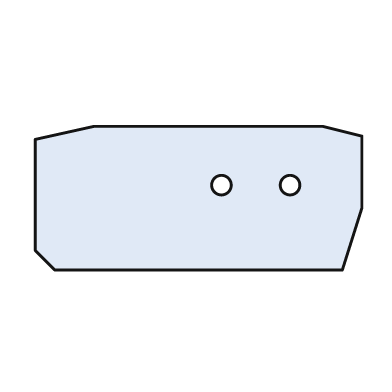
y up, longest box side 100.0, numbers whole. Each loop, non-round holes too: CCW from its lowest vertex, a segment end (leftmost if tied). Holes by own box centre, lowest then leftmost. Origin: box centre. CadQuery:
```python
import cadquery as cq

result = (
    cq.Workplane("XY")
    .moveTo(-44.0, -22.0)
    .lineTo(44.0, -22.0)
    .lineTo(50.0, -3.0)
    .lineTo(50.0, 19.0)
    .lineTo(38.0, 22.0)
    .lineTo(-32.0, 22.0)
    .lineTo(-50.0, 18.0)
    .lineTo(-50.0, -16.0)
    .close()
    .moveTo(7.0, 4.0)
    .circle(3.0)
    .moveTo(28.0, 4.0)
    .circle(3.0)
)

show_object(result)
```